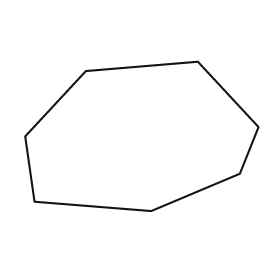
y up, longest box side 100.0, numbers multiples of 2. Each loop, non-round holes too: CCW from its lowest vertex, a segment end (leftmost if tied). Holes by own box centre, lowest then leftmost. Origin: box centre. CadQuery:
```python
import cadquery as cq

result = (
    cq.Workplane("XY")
    .moveTo(4.0, -32.0)
    .lineTo(42.0, -16.0)
    .lineTo(50.0, 4.0)
    .lineTo(24.0, 32.0)
    .lineTo(-24.0, 28.0)
    .lineTo(-50.0, 0.0)
    .lineTo(-46.0, -28.0)
    .close()
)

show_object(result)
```